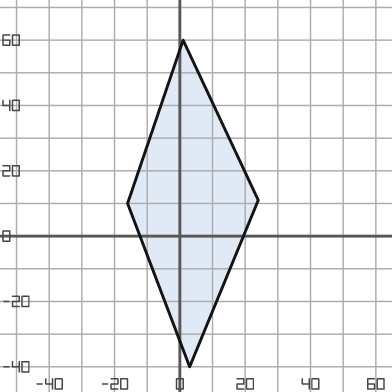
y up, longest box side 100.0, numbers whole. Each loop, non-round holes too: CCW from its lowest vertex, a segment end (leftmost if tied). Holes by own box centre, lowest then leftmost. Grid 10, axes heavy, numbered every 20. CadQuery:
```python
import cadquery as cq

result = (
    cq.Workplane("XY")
    .moveTo(3.0, -40.0)
    .lineTo(24.0, 11.0)
    .lineTo(1.0, 60.0)
    .lineTo(-16.0, 10.0)
    .close()
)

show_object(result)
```